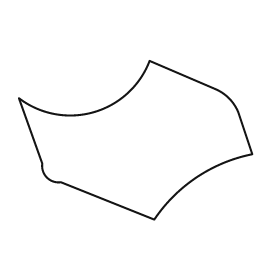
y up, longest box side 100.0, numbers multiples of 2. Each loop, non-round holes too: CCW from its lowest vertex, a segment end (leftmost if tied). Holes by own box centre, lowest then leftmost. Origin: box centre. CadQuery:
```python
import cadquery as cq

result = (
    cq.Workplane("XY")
    .moveTo(8.0, -34.0)
    .threePointArc((26.0, -16.0), (50.0, -6.0))
    .lineTo(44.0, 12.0)
    .threePointArc((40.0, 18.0), (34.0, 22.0))
    .lineTo(6.0, 34.0)
    .threePointArc((-18.0, 12.0), (-50.0, 18.0))
    .lineTo(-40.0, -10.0)
    .threePointArc((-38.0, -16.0), (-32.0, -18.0))
    .close()
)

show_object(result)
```